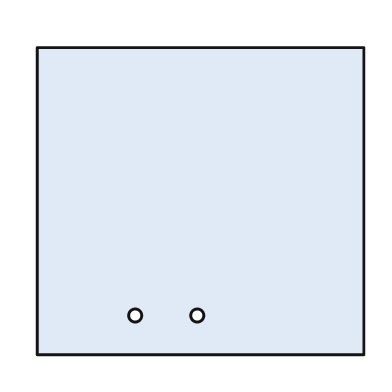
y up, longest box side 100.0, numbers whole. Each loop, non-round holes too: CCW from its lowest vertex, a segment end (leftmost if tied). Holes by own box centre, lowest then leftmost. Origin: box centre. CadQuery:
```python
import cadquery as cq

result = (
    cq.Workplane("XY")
    .moveTo(-50.0, -47.0)
    .lineTo(50.0, -47.0)
    .lineTo(50.0, 47.0)
    .lineTo(-50.0, 47.0)
    .close()
    .moveTo(-20.0, -35.0)
    .circle(2.0)
    .moveTo(-1.0, -35.0)
    .circle(2.0)
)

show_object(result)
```